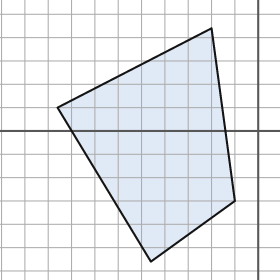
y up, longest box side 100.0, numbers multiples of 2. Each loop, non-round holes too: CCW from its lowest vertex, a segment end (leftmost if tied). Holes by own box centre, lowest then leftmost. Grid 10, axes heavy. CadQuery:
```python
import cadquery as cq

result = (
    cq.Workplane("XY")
    .moveTo(-46.0, -56.0)
    .lineTo(-10.0, -30.0)
    .lineTo(-20.0, 44.0)
    .lineTo(-86.0, 10.0)
    .close()
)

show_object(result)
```